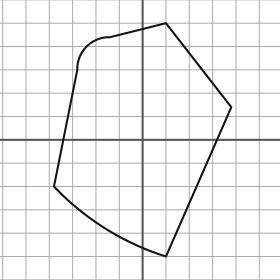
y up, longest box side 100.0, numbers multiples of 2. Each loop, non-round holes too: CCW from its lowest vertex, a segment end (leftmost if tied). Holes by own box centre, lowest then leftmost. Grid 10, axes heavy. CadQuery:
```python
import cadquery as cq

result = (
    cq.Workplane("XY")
    .moveTo(10.0, -50.0)
    .lineTo(38.0, 14.0)
    .lineTo(10.0, 50.0)
    .lineTo(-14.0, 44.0)
    .threePointArc((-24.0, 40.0), (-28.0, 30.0))
    .lineTo(-38.0, -20.0)
    .threePointArc((-16.0, -38.0), (10.0, -50.0))
    .close()
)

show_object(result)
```